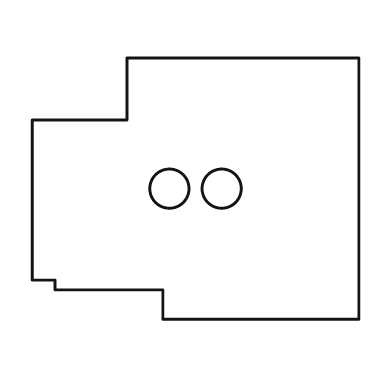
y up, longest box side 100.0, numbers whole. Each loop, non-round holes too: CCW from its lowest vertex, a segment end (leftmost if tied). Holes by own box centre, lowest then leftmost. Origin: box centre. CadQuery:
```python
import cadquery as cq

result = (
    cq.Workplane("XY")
    .moveTo(-10.0, -40.0)
    .lineTo(50.0, -40.0)
    .lineTo(50.0, 40.0)
    .lineTo(-21.0, 40.0)
    .lineTo(-21.0, 21.0)
    .lineTo(-50.0, 21.0)
    .lineTo(-50.0, -28.0)
    .lineTo(-43.0, -28.0)
    .lineTo(-43.0, -31.0)
    .lineTo(-10.0, -31.0)
    .close()
    .moveTo(-8.0, 0.0)
    .circle(6.0)
    .moveTo(8.0, 0.0)
    .circle(6.0)
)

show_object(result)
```